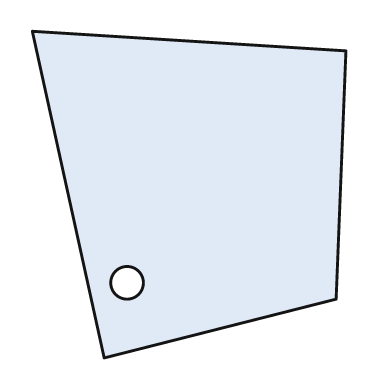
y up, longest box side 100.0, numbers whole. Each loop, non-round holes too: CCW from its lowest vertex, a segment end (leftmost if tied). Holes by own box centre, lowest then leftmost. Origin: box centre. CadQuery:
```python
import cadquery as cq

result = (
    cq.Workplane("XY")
    .moveTo(-26.0, -50.0)
    .lineTo(45.0, -32.0)
    .lineTo(48.0, 44.0)
    .lineTo(-48.0, 50.0)
    .close()
    .moveTo(-19.0, -27.0)
    .circle(5.0)
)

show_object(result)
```